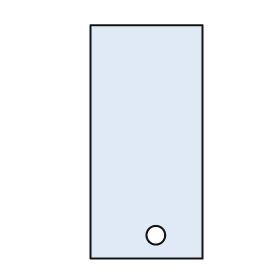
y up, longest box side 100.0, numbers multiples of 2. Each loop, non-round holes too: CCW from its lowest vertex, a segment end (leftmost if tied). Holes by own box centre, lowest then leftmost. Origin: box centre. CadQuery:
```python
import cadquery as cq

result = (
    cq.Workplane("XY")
    .moveTo(-24.0, -50.0)
    .lineTo(24.0, -50.0)
    .lineTo(24.0, 50.0)
    .lineTo(-24.0, 50.0)
    .close()
    .moveTo(4.0, -40.0)
    .circle(4.0)
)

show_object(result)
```